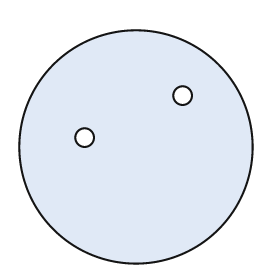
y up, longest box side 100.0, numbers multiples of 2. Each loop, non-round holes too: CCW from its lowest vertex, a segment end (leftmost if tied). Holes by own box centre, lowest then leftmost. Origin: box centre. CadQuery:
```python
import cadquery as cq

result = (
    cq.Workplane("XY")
    .moveTo(0.0, 0.0)
    .circle(50.0)
    .moveTo(-22.0, 4.0)
    .circle(4.0)
    .moveTo(20.0, 22.0)
    .circle(4.0)
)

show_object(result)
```